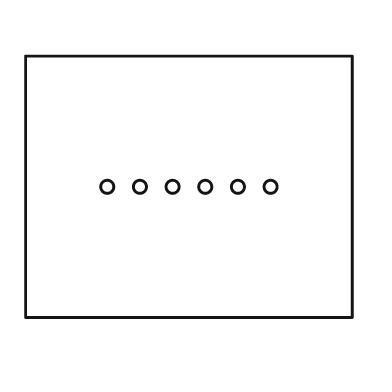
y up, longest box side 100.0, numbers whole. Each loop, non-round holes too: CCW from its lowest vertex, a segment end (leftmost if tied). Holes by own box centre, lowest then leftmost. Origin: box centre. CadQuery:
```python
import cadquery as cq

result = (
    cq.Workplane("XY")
    .moveTo(-50.0, -40.0)
    .lineTo(50.0, -40.0)
    .lineTo(50.0, 40.0)
    .lineTo(-50.0, 40.0)
    .close()
    .moveTo(-25.0, 0.0)
    .circle(2.0)
    .moveTo(-15.0, 0.0)
    .circle(2.0)
    .moveTo(-5.0, 0.0)
    .circle(2.0)
    .moveTo(5.0, 0.0)
    .circle(2.0)
    .moveTo(15.0, 0.0)
    .circle(2.0)
    .moveTo(25.0, 0.0)
    .circle(2.0)
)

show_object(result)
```